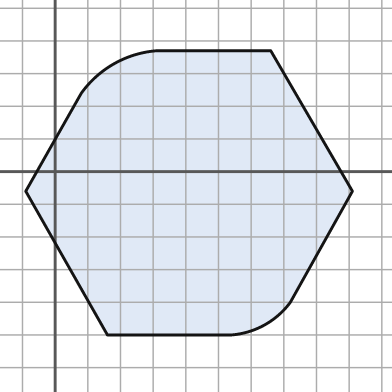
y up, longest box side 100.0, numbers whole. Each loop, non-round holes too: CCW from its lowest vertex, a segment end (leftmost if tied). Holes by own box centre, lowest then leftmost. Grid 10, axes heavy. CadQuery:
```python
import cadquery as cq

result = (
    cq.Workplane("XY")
    .moveTo(16.0, -50.0)
    .lineTo(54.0, -50.0)
    .threePointArc((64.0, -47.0), (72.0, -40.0))
    .lineTo(91.0, -6.0)
    .lineTo(66.0, 37.0)
    .lineTo(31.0, 37.0)
    .threePointArc((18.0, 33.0), (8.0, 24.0))
    .lineTo(-9.0, -6.0)
    .close()
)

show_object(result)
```